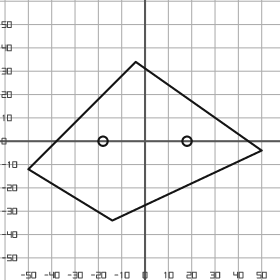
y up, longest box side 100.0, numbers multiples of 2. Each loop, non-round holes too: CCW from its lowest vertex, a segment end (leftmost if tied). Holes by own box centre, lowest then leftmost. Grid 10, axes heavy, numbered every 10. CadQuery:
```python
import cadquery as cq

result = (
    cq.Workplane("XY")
    .moveTo(-14.0, -34.0)
    .lineTo(50.0, -4.0)
    .lineTo(-4.0, 34.0)
    .lineTo(-50.0, -12.0)
    .close()
    .moveTo(-18.0, 0.0)
    .circle(2.0)
    .moveTo(18.0, 0.0)
    .circle(2.0)
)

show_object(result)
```